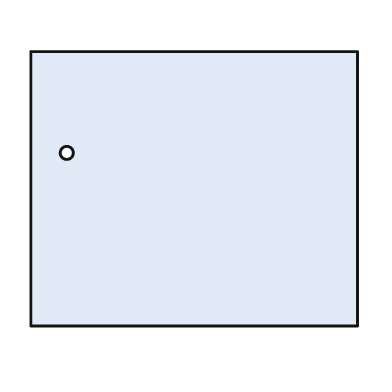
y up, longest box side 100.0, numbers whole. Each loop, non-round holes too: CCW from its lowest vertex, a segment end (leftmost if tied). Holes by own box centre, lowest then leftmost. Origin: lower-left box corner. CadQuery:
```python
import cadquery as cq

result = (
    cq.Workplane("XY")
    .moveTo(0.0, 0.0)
    .lineTo(100.0, 0.0)
    .lineTo(100.0, 84.0)
    .lineTo(0.0, 84.0)
    .close()
    .moveTo(11.0, 53.0)
    .circle(2.0)
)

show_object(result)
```